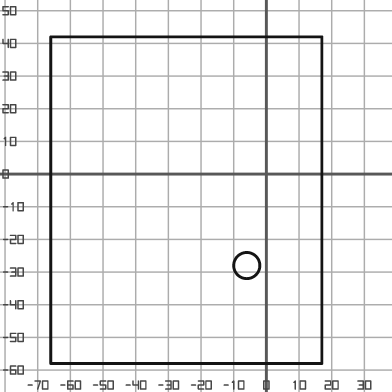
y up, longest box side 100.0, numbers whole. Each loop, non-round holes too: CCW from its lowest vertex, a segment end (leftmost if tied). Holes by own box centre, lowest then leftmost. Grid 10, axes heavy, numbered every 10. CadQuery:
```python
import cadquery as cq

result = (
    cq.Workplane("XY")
    .moveTo(-66.0, -58.0)
    .lineTo(17.0, -58.0)
    .lineTo(17.0, 42.0)
    .lineTo(-66.0, 42.0)
    .close()
    .moveTo(-6.0, -28.0)
    .circle(4.0)
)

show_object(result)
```